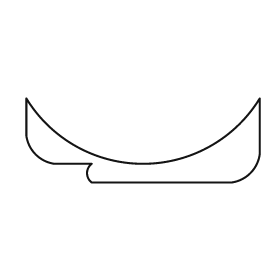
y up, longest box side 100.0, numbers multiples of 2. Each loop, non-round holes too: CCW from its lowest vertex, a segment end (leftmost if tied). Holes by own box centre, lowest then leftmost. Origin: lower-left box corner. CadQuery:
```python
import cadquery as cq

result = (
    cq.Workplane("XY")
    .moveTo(28.0, 0.0)
    .lineTo(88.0, 0.0)
    .threePointArc((96.0, 4.0), (100.0, 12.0))
    .lineTo(100.0, 36.0)
    .threePointArc((50.0, 8.0), (0.0, 36.0))
    .lineTo(0.0, 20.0)
    .threePointArc((4.0, 12.0), (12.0, 8.0))
    .lineTo(28.0, 8.0)
    .threePointArc((26.0, 4.0), (28.0, 0.0))
    .close()
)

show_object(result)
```